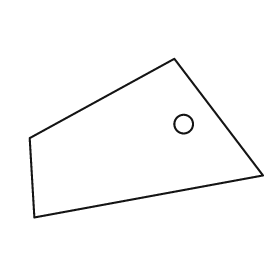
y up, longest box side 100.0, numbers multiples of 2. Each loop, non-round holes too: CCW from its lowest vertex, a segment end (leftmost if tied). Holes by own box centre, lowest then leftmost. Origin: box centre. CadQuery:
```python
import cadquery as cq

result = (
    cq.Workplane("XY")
    .moveTo(-48.0, -34.0)
    .lineTo(50.0, -16.0)
    .lineTo(12.0, 34.0)
    .lineTo(-50.0, 0.0)
    .close()
    .moveTo(16.0, 6.0)
    .circle(4.0)
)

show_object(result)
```